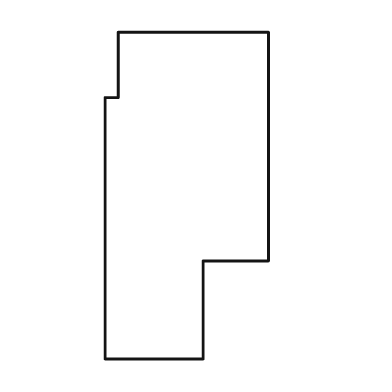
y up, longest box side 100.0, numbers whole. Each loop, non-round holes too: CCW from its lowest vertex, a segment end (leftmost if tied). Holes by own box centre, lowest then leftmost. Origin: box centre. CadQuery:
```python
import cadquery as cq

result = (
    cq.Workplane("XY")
    .moveTo(-25.0, -50.0)
    .lineTo(5.0, -50.0)
    .lineTo(5.0, -20.0)
    .lineTo(25.0, -20.0)
    .lineTo(25.0, 50.0)
    .lineTo(-21.0, 50.0)
    .lineTo(-21.0, 30.0)
    .lineTo(-25.0, 30.0)
    .close()
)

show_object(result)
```